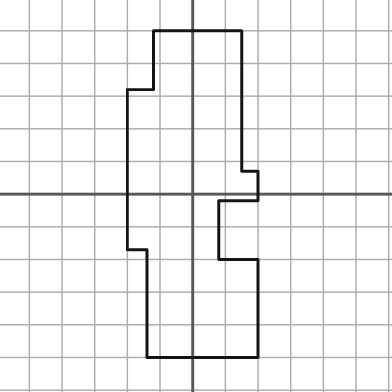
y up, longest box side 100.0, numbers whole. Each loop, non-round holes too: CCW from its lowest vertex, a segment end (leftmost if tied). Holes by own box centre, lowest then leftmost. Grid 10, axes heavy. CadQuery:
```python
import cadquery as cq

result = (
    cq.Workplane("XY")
    .moveTo(-14.0, -50.0)
    .lineTo(20.0, -50.0)
    .lineTo(20.0, -20.0)
    .lineTo(8.0, -20.0)
    .lineTo(8.0, -2.0)
    .lineTo(20.0, -2.0)
    .lineTo(20.0, 7.0)
    .lineTo(15.0, 7.0)
    .lineTo(15.0, 50.0)
    .lineTo(-12.0, 50.0)
    .lineTo(-12.0, 32.0)
    .lineTo(-20.0, 32.0)
    .lineTo(-20.0, -17.0)
    .lineTo(-14.0, -17.0)
    .close()
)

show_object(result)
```